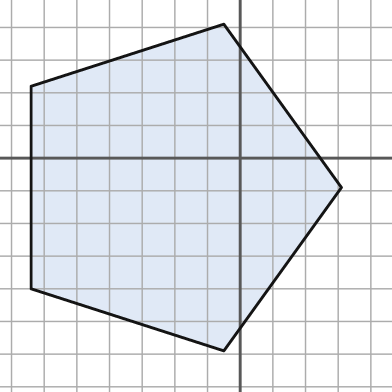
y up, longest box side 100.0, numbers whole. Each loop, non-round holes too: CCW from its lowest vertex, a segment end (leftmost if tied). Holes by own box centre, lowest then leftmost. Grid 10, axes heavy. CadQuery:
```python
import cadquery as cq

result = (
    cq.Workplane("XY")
    .moveTo(-5.0, -59.0)
    .lineTo(31.0, -9.0)
    .lineTo(-5.0, 41.0)
    .lineTo(-64.0, 22.0)
    .lineTo(-64.0, -40.0)
    .close()
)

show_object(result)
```